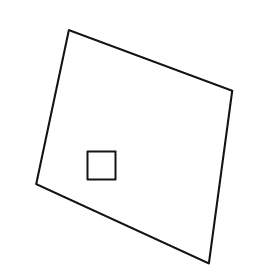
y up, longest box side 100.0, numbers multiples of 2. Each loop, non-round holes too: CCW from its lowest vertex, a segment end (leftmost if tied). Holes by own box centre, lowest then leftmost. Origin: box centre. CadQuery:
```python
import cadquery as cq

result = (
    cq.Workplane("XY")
    .moveTo(32.0, -50.0)
    .lineTo(42.0, 24.0)
    .lineTo(-28.0, 50.0)
    .lineTo(-42.0, -16.0)
    .close()
    .moveTo(-20.0, -14.0)
    .lineTo(-8.0, -14.0)
    .lineTo(-8.0, -2.0)
    .lineTo(-20.0, -2.0)
    .close()
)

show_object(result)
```